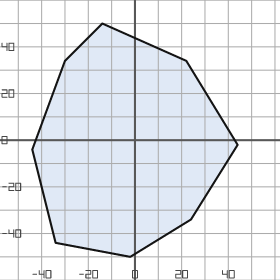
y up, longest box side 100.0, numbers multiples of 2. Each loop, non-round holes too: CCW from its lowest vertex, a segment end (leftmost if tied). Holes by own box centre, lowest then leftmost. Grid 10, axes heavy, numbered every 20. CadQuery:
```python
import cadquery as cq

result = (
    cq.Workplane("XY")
    .moveTo(-2.0, -50.0)
    .lineTo(24.0, -34.0)
    .lineTo(44.0, -2.0)
    .lineTo(22.0, 34.0)
    .lineTo(-14.0, 50.0)
    .lineTo(-30.0, 34.0)
    .lineTo(-44.0, -4.0)
    .lineTo(-34.0, -44.0)
    .close()
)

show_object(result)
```